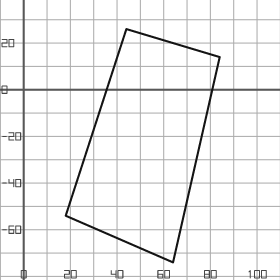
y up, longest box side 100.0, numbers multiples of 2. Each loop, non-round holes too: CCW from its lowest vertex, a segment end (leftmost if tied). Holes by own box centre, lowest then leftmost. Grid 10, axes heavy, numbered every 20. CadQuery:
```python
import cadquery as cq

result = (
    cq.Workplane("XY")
    .moveTo(64.0, -74.0)
    .lineTo(84.0, 14.0)
    .lineTo(44.0, 26.0)
    .lineTo(18.0, -54.0)
    .close()
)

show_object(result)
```